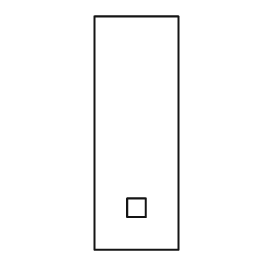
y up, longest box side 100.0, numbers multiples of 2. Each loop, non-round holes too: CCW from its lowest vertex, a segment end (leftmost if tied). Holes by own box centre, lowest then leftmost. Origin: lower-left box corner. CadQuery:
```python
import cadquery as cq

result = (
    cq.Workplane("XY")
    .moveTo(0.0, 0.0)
    .lineTo(36.0, 0.0)
    .lineTo(36.0, 100.0)
    .lineTo(0.0, 100.0)
    .close()
    .moveTo(14.0, 14.0)
    .lineTo(22.0, 14.0)
    .lineTo(22.0, 22.0)
    .lineTo(14.0, 22.0)
    .close()
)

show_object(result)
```